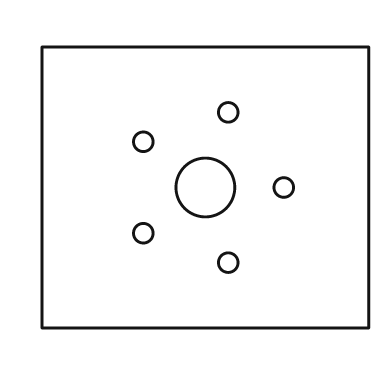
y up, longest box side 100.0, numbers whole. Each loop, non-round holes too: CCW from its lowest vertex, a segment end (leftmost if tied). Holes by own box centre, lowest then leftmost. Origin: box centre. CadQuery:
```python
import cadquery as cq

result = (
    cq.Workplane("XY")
    .moveTo(-50.0, -43.0)
    .lineTo(50.0, -43.0)
    .lineTo(50.0, 43.0)
    .lineTo(-50.0, 43.0)
    .close()
    .moveTo(7.0, -23.0)
    .circle(3.0)
    .moveTo(-19.0, -14.0)
    .circle(3.0)
    .moveTo(0.0, 0.0)
    .circle(9.0)
    .moveTo(24.0, 0.0)
    .circle(3.0)
    .moveTo(-19.0, 14.0)
    .circle(3.0)
    .moveTo(7.0, 23.0)
    .circle(3.0)
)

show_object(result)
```